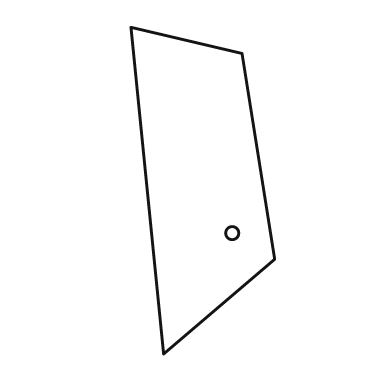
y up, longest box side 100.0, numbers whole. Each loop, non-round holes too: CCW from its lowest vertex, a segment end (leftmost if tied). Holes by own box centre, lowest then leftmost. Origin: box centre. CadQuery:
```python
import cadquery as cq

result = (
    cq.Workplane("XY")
    .moveTo(-12.0, -50.0)
    .lineTo(22.0, -21.0)
    .lineTo(12.0, 42.0)
    .lineTo(-22.0, 50.0)
    .close()
    .moveTo(9.0, -13.0)
    .circle(2.0)
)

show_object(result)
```